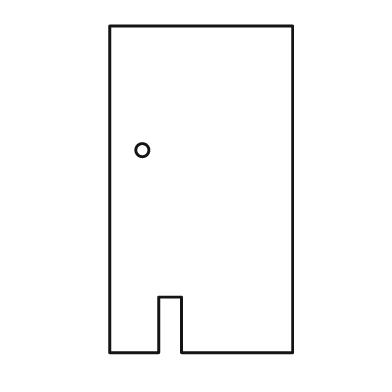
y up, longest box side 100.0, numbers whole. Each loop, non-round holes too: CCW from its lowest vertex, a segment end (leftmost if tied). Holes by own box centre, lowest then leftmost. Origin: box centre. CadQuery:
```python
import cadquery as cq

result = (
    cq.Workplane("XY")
    .moveTo(-28.0, -50.0)
    .lineTo(-13.0, -50.0)
    .lineTo(-13.0, -33.0)
    .lineTo(-6.0, -33.0)
    .lineTo(-6.0, -50.0)
    .lineTo(28.0, -50.0)
    .lineTo(28.0, 50.0)
    .lineTo(-28.0, 50.0)
    .close()
    .moveTo(-18.0, 12.0)
    .circle(2.0)
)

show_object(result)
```